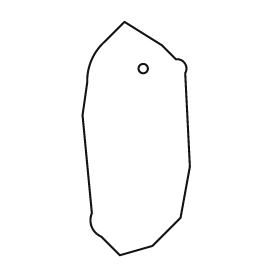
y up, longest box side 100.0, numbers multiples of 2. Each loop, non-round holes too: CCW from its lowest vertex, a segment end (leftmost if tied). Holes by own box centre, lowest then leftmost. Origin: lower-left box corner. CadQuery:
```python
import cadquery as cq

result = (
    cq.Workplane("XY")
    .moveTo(16.0, 0.0)
    .lineTo(30.0, 4.0)
    .lineTo(42.0, 16.0)
    .lineTo(46.0, 38.0)
    .lineTo(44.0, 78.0)
    .threePointArc((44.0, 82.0), (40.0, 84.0))
    .lineTo(34.0, 90.0)
    .lineTo(18.0, 100.0)
    .lineTo(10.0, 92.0)
    .threePointArc((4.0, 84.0), (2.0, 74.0))
    .lineTo(0.0, 60.0)
    .lineTo(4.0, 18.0)
    .threePointArc((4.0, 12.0), (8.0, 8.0))
    .close()
    .moveTo(26.0, 80.0)
    .circle(2.0)
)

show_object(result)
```